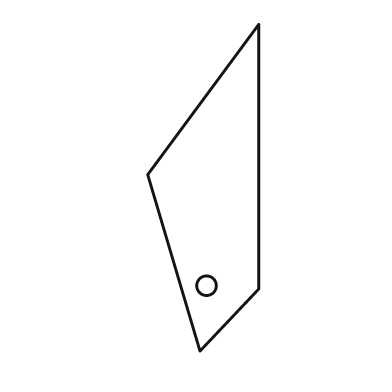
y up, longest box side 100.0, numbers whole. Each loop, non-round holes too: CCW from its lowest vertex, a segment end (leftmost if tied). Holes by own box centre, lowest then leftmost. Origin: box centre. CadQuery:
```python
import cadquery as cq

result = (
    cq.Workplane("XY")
    .moveTo(-1.0, -50.0)
    .lineTo(17.0, -31.0)
    .lineTo(17.0, 50.0)
    .lineTo(-17.0, 4.0)
    .close()
    .moveTo(1.0, -30.0)
    .circle(3.0)
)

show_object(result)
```